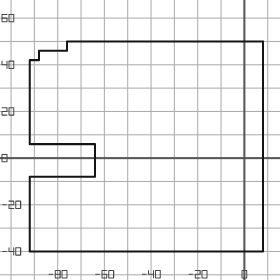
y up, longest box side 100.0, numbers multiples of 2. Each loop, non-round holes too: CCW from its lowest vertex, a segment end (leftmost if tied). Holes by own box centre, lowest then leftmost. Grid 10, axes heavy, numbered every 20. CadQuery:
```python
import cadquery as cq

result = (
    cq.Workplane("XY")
    .moveTo(-92.0, -40.0)
    .lineTo(8.0, -40.0)
    .lineTo(8.0, 50.0)
    .lineTo(-76.0, 50.0)
    .lineTo(-76.0, 46.0)
    .lineTo(-88.0, 46.0)
    .lineTo(-88.0, 42.0)
    .lineTo(-92.0, 42.0)
    .lineTo(-92.0, 6.0)
    .lineTo(-64.0, 6.0)
    .lineTo(-64.0, -8.0)
    .lineTo(-92.0, -8.0)
    .close()
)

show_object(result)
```